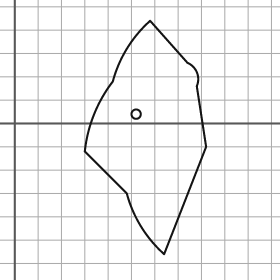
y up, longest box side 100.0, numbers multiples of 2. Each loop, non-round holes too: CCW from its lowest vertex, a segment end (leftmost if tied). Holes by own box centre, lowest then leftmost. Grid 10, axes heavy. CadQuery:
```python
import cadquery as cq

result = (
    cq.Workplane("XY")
    .moveTo(64.0, -56.0)
    .lineTo(82.0, -10.0)
    .lineTo(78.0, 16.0)
    .threePointArc((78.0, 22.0), (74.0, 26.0))
    .lineTo(58.0, 44.0)
    .threePointArc((48.0, 32.0), (42.0, 18.0))
    .threePointArc((34.0, 4.0), (30.0, -12.0))
    .lineTo(48.0, -30.0)
    .threePointArc((54.0, -44.0), (64.0, -56.0))
    .close()
    .moveTo(52.0, 4.0)
    .circle(2.0)
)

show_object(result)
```